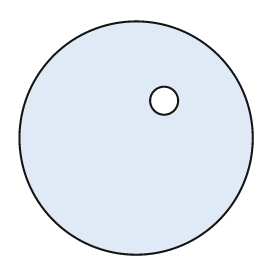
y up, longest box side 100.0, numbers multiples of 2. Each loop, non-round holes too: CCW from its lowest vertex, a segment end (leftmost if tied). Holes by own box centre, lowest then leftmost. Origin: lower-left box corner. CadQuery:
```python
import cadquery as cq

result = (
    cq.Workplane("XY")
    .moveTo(50.0, 50.0)
    .circle(50.0)
    .moveTo(62.0, 66.0)
    .circle(6.0)
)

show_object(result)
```